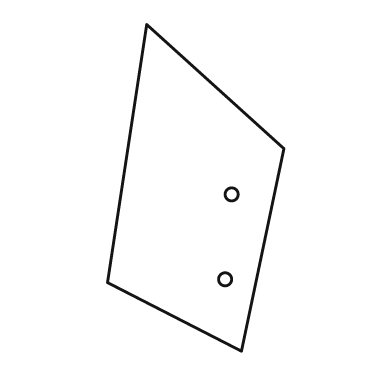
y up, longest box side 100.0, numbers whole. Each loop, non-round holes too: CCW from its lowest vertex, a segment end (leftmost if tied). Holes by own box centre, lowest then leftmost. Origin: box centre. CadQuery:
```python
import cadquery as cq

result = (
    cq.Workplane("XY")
    .moveTo(14.0, -50.0)
    .lineTo(27.0, 12.0)
    .lineTo(-15.0, 50.0)
    .lineTo(-27.0, -29.0)
    .close()
    .moveTo(9.0, -28.0)
    .circle(2.0)
    .moveTo(11.0, -2.0)
    .circle(2.0)
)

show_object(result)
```